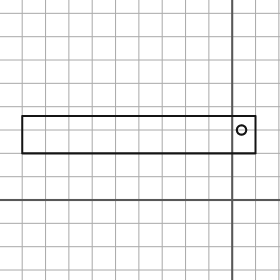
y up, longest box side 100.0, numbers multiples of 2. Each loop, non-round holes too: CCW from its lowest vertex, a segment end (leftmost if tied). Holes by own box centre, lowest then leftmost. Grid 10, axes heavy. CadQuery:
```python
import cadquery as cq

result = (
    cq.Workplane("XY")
    .moveTo(-90.0, 20.0)
    .lineTo(10.0, 20.0)
    .lineTo(10.0, 36.0)
    .lineTo(-90.0, 36.0)
    .close()
    .moveTo(4.0, 30.0)
    .circle(2.0)
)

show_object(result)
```